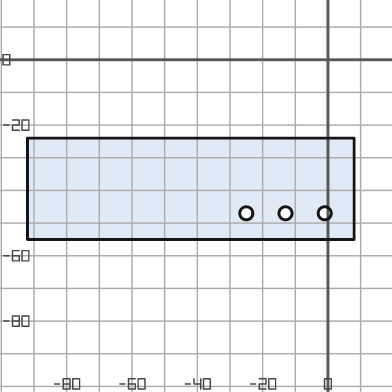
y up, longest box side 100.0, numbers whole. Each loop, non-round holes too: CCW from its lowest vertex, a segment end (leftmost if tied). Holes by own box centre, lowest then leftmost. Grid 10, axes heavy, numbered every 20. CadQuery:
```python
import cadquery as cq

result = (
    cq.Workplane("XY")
    .moveTo(-92.0, -55.0)
    .lineTo(8.0, -55.0)
    .lineTo(8.0, -24.0)
    .lineTo(-92.0, -24.0)
    .close()
    .moveTo(-25.0, -47.0)
    .circle(2.0)
    .moveTo(-13.0, -47.0)
    .circle(2.0)
    .moveTo(-1.0, -47.0)
    .circle(2.0)
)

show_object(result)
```